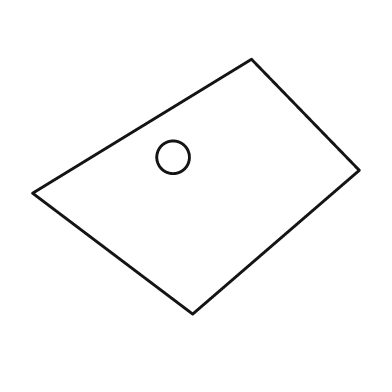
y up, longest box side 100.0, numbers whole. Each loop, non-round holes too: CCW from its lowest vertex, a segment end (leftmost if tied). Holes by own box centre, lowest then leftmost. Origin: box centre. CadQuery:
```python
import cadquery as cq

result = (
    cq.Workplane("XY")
    .moveTo(-1.0, -39.0)
    .lineTo(50.0, 5.0)
    .lineTo(17.0, 39.0)
    .lineTo(-50.0, -2.0)
    .close()
    .moveTo(-7.0, 9.0)
    .circle(5.0)
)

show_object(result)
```